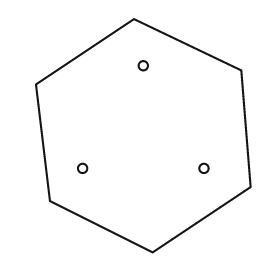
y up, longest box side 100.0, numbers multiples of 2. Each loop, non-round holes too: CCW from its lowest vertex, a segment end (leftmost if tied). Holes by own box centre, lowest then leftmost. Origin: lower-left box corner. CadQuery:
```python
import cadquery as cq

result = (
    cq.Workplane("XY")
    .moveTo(50.0, 0.0)
    .lineTo(92.0, 28.0)
    .lineTo(88.0, 78.0)
    .lineTo(42.0, 100.0)
    .lineTo(0.0, 72.0)
    .lineTo(6.0, 22.0)
    .close()
    .moveTo(20.0, 36.0)
    .circle(2.0)
    .moveTo(72.0, 36.0)
    .circle(2.0)
    .moveTo(46.0, 80.0)
    .circle(2.0)
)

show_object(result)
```